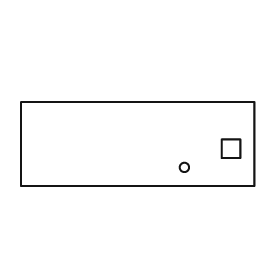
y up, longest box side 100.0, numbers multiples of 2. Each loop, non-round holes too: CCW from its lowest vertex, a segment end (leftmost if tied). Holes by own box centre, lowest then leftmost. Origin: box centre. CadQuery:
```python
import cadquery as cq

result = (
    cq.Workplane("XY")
    .moveTo(-50.0, -18.0)
    .lineTo(50.0, -18.0)
    .lineTo(50.0, 18.0)
    .lineTo(-50.0, 18.0)
    .close()
    .moveTo(20.0, -10.0)
    .circle(2.0)
    .moveTo(36.0, -6.0)
    .lineTo(44.0, -6.0)
    .lineTo(44.0, 2.0)
    .lineTo(36.0, 2.0)
    .close()
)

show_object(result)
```